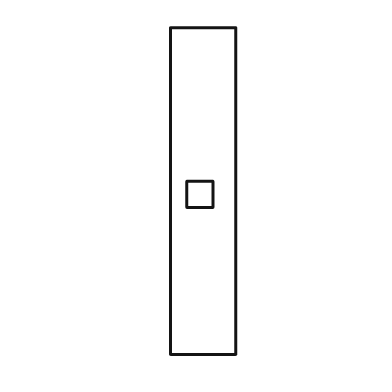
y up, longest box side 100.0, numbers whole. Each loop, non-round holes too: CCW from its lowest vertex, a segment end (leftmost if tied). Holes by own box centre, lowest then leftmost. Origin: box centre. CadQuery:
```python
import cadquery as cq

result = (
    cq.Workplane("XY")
    .moveTo(-10.0, -50.0)
    .lineTo(10.0, -50.0)
    .lineTo(10.0, 50.0)
    .lineTo(-10.0, 50.0)
    .close()
    .moveTo(-5.0, -5.0)
    .lineTo(3.0, -5.0)
    .lineTo(3.0, 3.0)
    .lineTo(-5.0, 3.0)
    .close()
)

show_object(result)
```